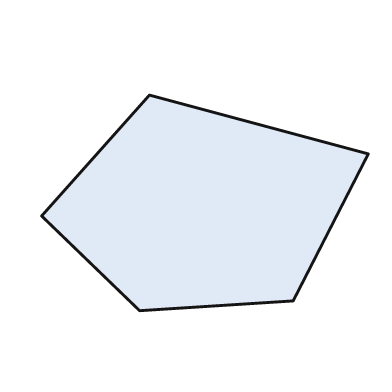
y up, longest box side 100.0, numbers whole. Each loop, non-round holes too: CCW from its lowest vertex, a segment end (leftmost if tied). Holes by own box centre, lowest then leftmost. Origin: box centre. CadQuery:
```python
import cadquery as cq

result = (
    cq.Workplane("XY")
    .moveTo(-20.0, -33.0)
    .lineTo(27.0, -30.0)
    .lineTo(50.0, 15.0)
    .lineTo(-17.0, 33.0)
    .lineTo(-50.0, -4.0)
    .close()
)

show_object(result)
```